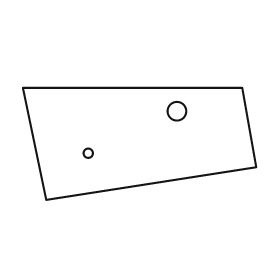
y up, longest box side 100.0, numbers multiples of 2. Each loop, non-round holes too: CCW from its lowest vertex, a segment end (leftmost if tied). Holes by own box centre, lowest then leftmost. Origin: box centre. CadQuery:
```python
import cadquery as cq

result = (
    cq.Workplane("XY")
    .moveTo(-40.0, -24.0)
    .lineTo(50.0, -10.0)
    .lineTo(44.0, 24.0)
    .lineTo(-50.0, 24.0)
    .close()
    .moveTo(-22.0, -4.0)
    .circle(2.0)
    .moveTo(16.0, 14.0)
    .circle(4.0)
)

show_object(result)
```